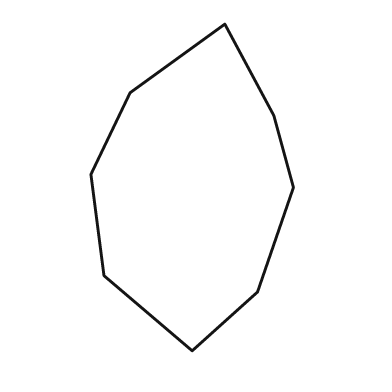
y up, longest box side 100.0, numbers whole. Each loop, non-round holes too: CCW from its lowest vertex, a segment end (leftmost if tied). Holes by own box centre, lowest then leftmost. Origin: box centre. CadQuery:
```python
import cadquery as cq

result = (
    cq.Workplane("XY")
    .moveTo(0.0, -50.0)
    .lineTo(20.0, -32.0)
    .lineTo(31.0, 0.0)
    .lineTo(25.0, 22.0)
    .lineTo(10.0, 50.0)
    .lineTo(-19.0, 29.0)
    .lineTo(-31.0, 4.0)
    .lineTo(-27.0, -27.0)
    .close()
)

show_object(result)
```